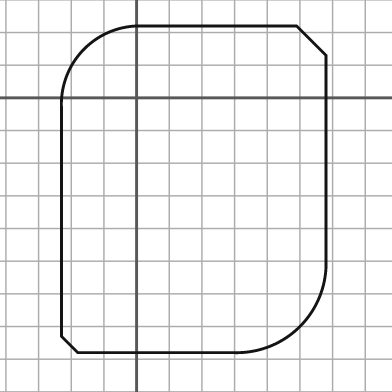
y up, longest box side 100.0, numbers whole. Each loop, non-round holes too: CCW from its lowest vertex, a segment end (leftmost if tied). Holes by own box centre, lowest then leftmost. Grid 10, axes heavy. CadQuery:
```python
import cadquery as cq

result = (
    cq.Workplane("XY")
    .moveTo(-18.0, -78.0)
    .lineTo(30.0, -78.0)
    .threePointArc((50.0, -70.0), (58.0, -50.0))
    .lineTo(58.0, 13.0)
    .lineTo(49.0, 22.0)
    .lineTo(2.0, 22.0)
    .threePointArc((-16.0, 15.0), (-23.0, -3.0))
    .lineTo(-23.0, -73.0)
    .close()
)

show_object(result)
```